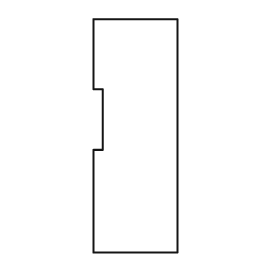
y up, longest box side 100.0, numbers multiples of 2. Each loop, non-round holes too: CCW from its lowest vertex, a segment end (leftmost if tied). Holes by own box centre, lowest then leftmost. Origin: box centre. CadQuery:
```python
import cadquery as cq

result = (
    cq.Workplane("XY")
    .moveTo(-18.0, -50.0)
    .lineTo(18.0, -50.0)
    .lineTo(18.0, 50.0)
    .lineTo(-18.0, 50.0)
    .lineTo(-18.0, 20.0)
    .lineTo(-14.0, 20.0)
    .lineTo(-14.0, -6.0)
    .lineTo(-18.0, -6.0)
    .close()
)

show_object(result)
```